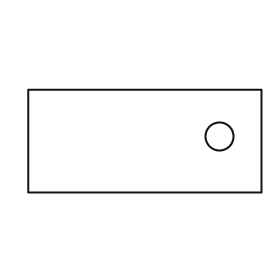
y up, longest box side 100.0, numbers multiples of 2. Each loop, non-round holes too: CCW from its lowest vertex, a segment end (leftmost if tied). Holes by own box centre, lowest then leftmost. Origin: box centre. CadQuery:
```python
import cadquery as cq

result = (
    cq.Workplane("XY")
    .moveTo(-50.0, -22.0)
    .lineTo(50.0, -22.0)
    .lineTo(50.0, 22.0)
    .lineTo(-50.0, 22.0)
    .close()
    .moveTo(32.0, 2.0)
    .circle(6.0)
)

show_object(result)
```